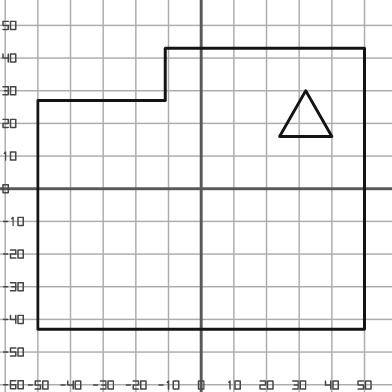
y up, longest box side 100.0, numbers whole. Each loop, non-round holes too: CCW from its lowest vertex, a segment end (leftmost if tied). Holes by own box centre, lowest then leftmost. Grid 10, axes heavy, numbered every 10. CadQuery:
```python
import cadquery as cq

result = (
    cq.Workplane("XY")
    .moveTo(-50.0, -43.0)
    .lineTo(50.0, -43.0)
    .lineTo(50.0, 43.0)
    .lineTo(-11.0, 43.0)
    .lineTo(-11.0, 27.0)
    .lineTo(-50.0, 27.0)
    .close()
    .moveTo(24.0, 16.0)
    .lineTo(40.0, 16.0)
    .lineTo(32.0, 30.0)
    .close()
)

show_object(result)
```